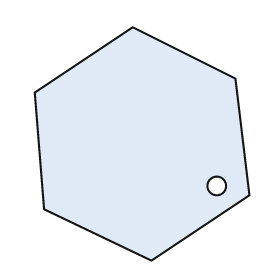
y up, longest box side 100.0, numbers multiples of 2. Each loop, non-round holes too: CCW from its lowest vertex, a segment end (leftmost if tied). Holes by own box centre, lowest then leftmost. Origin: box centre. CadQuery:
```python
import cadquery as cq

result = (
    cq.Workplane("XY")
    .moveTo(4.0, -50.0)
    .lineTo(46.0, -22.0)
    .lineTo(40.0, 28.0)
    .lineTo(-4.0, 50.0)
    .lineTo(-46.0, 22.0)
    .lineTo(-42.0, -28.0)
    .close()
    .moveTo(32.0, -18.0)
    .circle(4.0)
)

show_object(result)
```